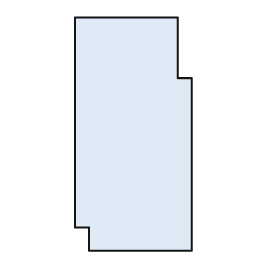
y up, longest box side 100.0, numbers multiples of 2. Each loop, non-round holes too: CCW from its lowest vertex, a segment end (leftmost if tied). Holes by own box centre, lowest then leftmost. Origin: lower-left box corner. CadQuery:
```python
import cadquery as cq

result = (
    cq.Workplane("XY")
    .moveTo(6.0, 0.0)
    .lineTo(50.0, 0.0)
    .lineTo(50.0, 74.0)
    .lineTo(44.0, 74.0)
    .lineTo(44.0, 100.0)
    .lineTo(0.0, 100.0)
    .lineTo(0.0, 10.0)
    .lineTo(6.0, 10.0)
    .close()
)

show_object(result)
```